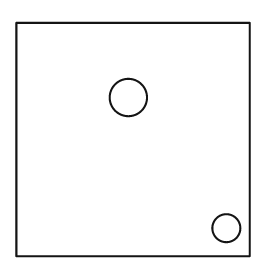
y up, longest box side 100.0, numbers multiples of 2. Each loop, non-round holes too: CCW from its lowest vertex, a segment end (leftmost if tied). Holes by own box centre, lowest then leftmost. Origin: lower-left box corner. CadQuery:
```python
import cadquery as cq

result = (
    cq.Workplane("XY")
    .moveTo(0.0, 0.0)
    .lineTo(100.0, 0.0)
    .lineTo(100.0, 100.0)
    .lineTo(0.0, 100.0)
    .close()
    .moveTo(90.0, 12.0)
    .circle(6.0)
    .moveTo(48.0, 68.0)
    .circle(8.0)
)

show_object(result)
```